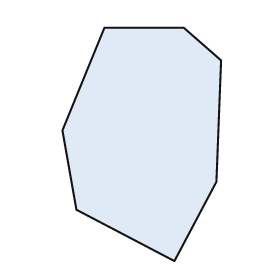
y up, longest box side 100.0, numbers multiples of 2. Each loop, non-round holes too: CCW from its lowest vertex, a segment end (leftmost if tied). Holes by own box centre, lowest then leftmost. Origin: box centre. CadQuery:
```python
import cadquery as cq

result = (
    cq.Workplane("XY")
    .moveTo(14.0, -50.0)
    .lineTo(32.0, -16.0)
    .lineTo(34.0, 36.0)
    .lineTo(18.0, 50.0)
    .lineTo(-16.0, 50.0)
    .lineTo(-34.0, 6.0)
    .lineTo(-28.0, -28.0)
    .close()
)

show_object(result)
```